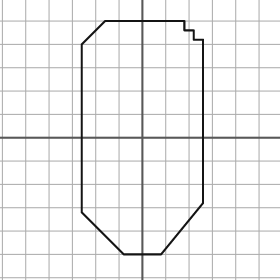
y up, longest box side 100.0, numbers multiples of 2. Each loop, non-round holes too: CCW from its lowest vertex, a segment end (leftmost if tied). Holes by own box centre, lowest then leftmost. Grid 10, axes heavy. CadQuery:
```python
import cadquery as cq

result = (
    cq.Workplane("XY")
    .moveTo(-8.0, -50.0)
    .lineTo(8.0, -50.0)
    .lineTo(26.0, -28.0)
    .lineTo(26.0, 42.0)
    .lineTo(22.0, 42.0)
    .lineTo(22.0, 46.0)
    .lineTo(18.0, 46.0)
    .lineTo(18.0, 50.0)
    .lineTo(-16.0, 50.0)
    .lineTo(-26.0, 40.0)
    .lineTo(-26.0, -32.0)
    .close()
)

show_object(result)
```